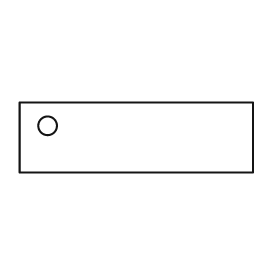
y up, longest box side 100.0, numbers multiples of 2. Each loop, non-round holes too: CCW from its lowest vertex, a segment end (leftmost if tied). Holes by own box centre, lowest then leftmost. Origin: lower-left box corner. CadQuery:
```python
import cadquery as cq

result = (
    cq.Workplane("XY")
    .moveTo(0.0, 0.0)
    .lineTo(100.0, 0.0)
    .lineTo(100.0, 30.0)
    .lineTo(0.0, 30.0)
    .close()
    .moveTo(12.0, 20.0)
    .circle(4.0)
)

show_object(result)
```